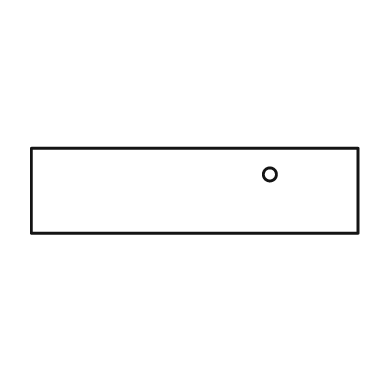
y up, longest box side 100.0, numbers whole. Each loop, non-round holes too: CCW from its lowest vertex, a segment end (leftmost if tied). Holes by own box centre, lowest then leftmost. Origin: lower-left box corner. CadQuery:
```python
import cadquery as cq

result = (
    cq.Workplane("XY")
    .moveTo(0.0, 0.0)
    .lineTo(100.0, 0.0)
    .lineTo(100.0, 26.0)
    .lineTo(0.0, 26.0)
    .close()
    .moveTo(73.0, 18.0)
    .circle(2.0)
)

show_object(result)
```